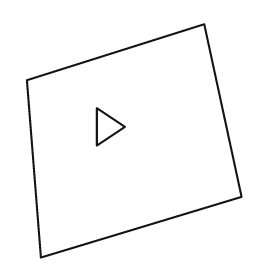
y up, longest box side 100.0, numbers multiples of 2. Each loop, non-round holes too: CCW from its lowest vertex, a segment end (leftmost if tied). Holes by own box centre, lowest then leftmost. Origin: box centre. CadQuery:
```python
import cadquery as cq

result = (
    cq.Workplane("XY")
    .moveTo(-40.0, -50.0)
    .lineTo(46.0, -24.0)
    .lineTo(30.0, 50.0)
    .lineTo(-46.0, 26.0)
    .close()
    .moveTo(-16.0, -2.0)
    .lineTo(-4.0, 6.0)
    .lineTo(-16.0, 14.0)
    .close()
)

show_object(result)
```